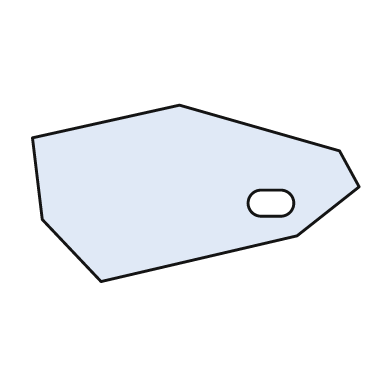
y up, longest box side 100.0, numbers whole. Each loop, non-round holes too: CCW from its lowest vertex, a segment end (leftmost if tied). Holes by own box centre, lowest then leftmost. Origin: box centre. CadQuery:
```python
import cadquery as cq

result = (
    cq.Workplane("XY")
    .moveTo(-29.0, -27.0)
    .lineTo(31.0, -13.0)
    .lineTo(50.0, 2.0)
    .lineTo(44.0, 13.0)
    .lineTo(-5.0, 27.0)
    .lineTo(-50.0, 17.0)
    .lineTo(-47.0, -8.0)
    .close()
    .moveTo(20.0, -7.0)
    .lineTo(26.0, -7.0)
    .threePointArc((30.0, -3.0), (26.0, 1.0))
    .lineTo(20.0, 1.0)
    .threePointArc((16.0, -3.0), (20.0, -7.0))
    .close()
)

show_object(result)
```